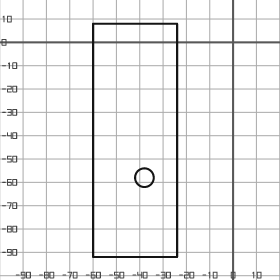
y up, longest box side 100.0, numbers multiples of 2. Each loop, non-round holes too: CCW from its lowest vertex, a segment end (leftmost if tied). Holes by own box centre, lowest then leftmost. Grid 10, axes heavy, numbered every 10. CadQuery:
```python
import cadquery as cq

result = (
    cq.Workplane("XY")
    .moveTo(-60.0, -92.0)
    .lineTo(-24.0, -92.0)
    .lineTo(-24.0, 8.0)
    .lineTo(-60.0, 8.0)
    .close()
    .moveTo(-38.0, -58.0)
    .circle(4.0)
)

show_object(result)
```